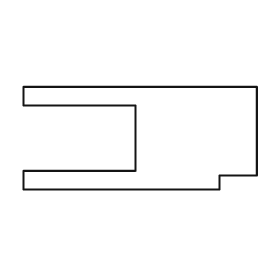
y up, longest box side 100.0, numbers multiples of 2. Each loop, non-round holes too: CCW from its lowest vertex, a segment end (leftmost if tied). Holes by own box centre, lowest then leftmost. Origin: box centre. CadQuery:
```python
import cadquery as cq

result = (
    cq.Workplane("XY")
    .moveTo(-50.0, -22.0)
    .lineTo(34.0, -22.0)
    .lineTo(34.0, -16.0)
    .lineTo(50.0, -16.0)
    .lineTo(50.0, 22.0)
    .lineTo(-50.0, 22.0)
    .lineTo(-50.0, 14.0)
    .lineTo(-2.0, 14.0)
    .lineTo(-2.0, -14.0)
    .lineTo(-50.0, -14.0)
    .close()
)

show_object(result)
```